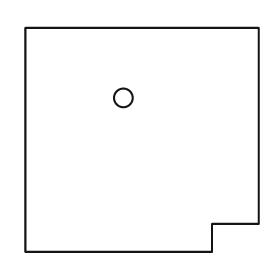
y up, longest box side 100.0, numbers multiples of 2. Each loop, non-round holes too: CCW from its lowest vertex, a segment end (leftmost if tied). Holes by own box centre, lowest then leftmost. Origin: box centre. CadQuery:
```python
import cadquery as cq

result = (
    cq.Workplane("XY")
    .moveTo(-50.0, -48.0)
    .lineTo(30.0, -48.0)
    .lineTo(30.0, -36.0)
    .lineTo(50.0, -36.0)
    .lineTo(50.0, 48.0)
    .lineTo(-50.0, 48.0)
    .close()
    .moveTo(-8.0, 18.0)
    .circle(4.0)
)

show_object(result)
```